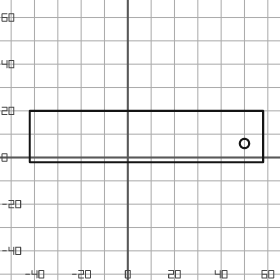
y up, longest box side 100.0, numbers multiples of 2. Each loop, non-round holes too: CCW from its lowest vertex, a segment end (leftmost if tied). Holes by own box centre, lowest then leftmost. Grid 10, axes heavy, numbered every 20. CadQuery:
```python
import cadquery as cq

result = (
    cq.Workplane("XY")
    .moveTo(-42.0, -2.0)
    .lineTo(58.0, -2.0)
    .lineTo(58.0, 20.0)
    .lineTo(-42.0, 20.0)
    .close()
    .moveTo(50.0, 6.0)
    .circle(2.0)
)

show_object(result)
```